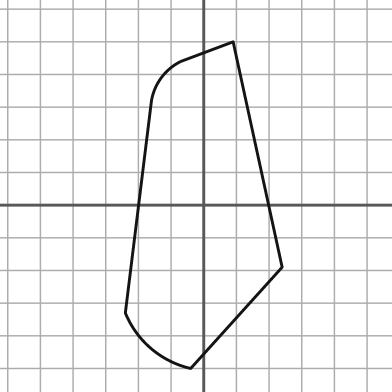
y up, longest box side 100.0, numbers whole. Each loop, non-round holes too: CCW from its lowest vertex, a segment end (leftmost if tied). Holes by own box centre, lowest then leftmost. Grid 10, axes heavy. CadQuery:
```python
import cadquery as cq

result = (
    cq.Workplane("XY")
    .moveTo(-4.0, -50.0)
    .lineTo(24.0, -19.0)
    .lineTo(9.0, 50.0)
    .lineTo(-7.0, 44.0)
    .threePointArc((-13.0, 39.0), (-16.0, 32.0))
    .lineTo(-24.0, -33.0)
    .threePointArc((-16.0, -44.0), (-4.0, -50.0))
    .close()
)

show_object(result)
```